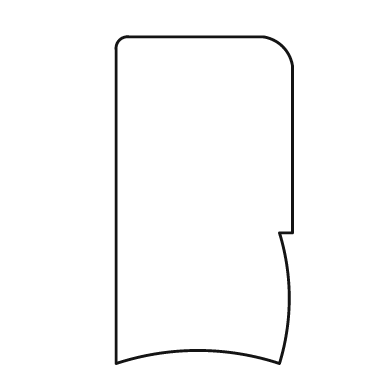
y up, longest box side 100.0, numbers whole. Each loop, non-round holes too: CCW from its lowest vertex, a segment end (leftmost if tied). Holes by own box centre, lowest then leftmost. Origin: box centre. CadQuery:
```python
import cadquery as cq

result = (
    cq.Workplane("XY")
    .moveTo(-27.0, -50.0)
    .threePointArc((-2.0, -46.0), (23.0, -50.0))
    .threePointArc((26.0, -30.0), (23.0, -10.0))
    .lineTo(27.0, -10.0)
    .lineTo(27.0, 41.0)
    .threePointArc((24.0, 47.0), (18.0, 50.0))
    .lineTo(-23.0, 50.0)
    .threePointArc((-26.0, 49.0), (-27.0, 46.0))
    .close()
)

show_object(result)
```